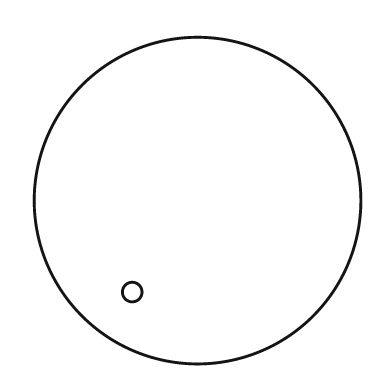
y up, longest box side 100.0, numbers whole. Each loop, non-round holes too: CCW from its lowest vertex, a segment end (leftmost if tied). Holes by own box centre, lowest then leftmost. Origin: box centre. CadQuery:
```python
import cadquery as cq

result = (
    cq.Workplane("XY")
    .moveTo(0.0, 0.0)
    .circle(50.0)
    .moveTo(-20.0, -28.0)
    .circle(3.0)
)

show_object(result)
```